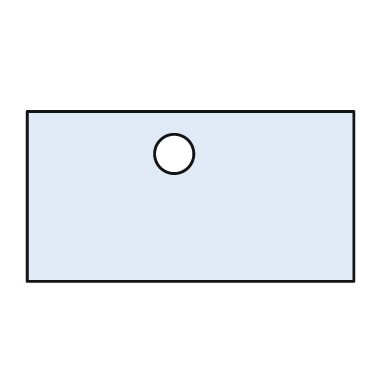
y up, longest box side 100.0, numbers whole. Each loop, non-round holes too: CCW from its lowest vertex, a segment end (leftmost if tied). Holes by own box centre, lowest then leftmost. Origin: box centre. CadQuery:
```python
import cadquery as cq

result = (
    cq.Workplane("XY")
    .moveTo(-50.0, -26.0)
    .lineTo(50.0, -26.0)
    .lineTo(50.0, 26.0)
    .lineTo(-50.0, 26.0)
    .close()
    .moveTo(-5.0, 13.0)
    .circle(6.0)
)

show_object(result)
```